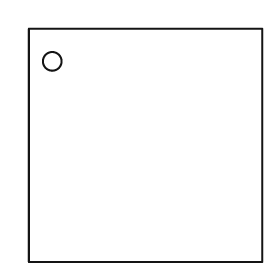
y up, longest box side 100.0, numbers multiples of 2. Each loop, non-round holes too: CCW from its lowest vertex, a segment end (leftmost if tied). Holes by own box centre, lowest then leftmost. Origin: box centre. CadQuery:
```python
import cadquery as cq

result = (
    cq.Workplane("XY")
    .moveTo(-50.0, -50.0)
    .lineTo(50.0, -50.0)
    .lineTo(50.0, 50.0)
    .lineTo(-50.0, 50.0)
    .close()
    .moveTo(-40.0, 36.0)
    .circle(4.0)
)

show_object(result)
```